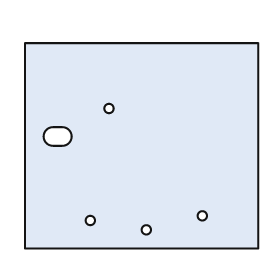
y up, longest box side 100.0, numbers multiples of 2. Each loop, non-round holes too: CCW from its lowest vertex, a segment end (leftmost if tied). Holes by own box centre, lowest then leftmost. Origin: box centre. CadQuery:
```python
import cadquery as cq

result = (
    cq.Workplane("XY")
    .moveTo(-50.0, -44.0)
    .lineTo(50.0, -44.0)
    .lineTo(50.0, 44.0)
    .lineTo(-50.0, 44.0)
    .close()
    .moveTo(2.0, -36.0)
    .circle(2.0)
    .moveTo(-22.0, -32.0)
    .circle(2.0)
    .moveTo(26.0, -30.0)
    .circle(2.0)
    .moveTo(-38.0, 0.0)
    .lineTo(-34.0, 0.0)
    .threePointArc((-30.0, 4.0), (-34.0, 8.0))
    .lineTo(-38.0, 8.0)
    .threePointArc((-42.0, 4.0), (-38.0, 0.0))
    .close()
    .moveTo(-14.0, 16.0)
    .circle(2.0)
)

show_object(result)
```